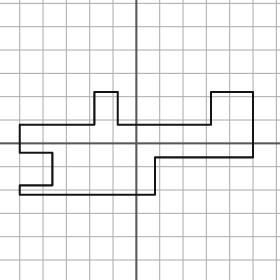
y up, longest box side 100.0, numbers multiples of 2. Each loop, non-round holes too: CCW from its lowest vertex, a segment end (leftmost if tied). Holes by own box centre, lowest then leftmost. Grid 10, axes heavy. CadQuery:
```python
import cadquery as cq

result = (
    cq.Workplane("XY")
    .moveTo(-50.0, -22.0)
    .lineTo(8.0, -22.0)
    .lineTo(8.0, -6.0)
    .lineTo(50.0, -6.0)
    .lineTo(50.0, 22.0)
    .lineTo(32.0, 22.0)
    .lineTo(32.0, 8.0)
    .lineTo(-8.0, 8.0)
    .lineTo(-8.0, 22.0)
    .lineTo(-18.0, 22.0)
    .lineTo(-18.0, 8.0)
    .lineTo(-50.0, 8.0)
    .lineTo(-50.0, -4.0)
    .lineTo(-36.0, -4.0)
    .lineTo(-36.0, -18.0)
    .lineTo(-50.0, -18.0)
    .close()
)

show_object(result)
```